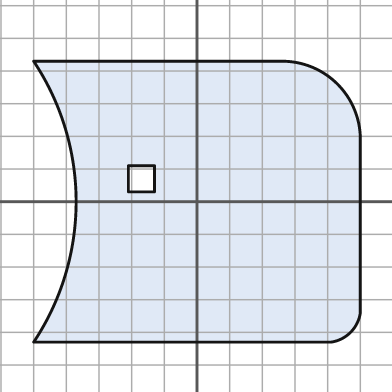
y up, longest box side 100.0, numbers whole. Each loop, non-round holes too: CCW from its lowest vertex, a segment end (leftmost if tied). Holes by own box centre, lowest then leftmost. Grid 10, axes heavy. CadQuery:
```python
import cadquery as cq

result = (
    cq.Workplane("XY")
    .moveTo(-50.0, -43.0)
    .lineTo(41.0, -43.0)
    .threePointArc((47.0, -40.0), (50.0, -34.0))
    .lineTo(50.0, 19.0)
    .threePointArc((43.0, 36.0), (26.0, 43.0))
    .lineTo(-50.0, 43.0)
    .threePointArc((-37.0, 0.0), (-50.0, -43.0))
    .close()
    .moveTo(-21.0, 3.0)
    .lineTo(-13.0, 3.0)
    .lineTo(-13.0, 11.0)
    .lineTo(-21.0, 11.0)
    .close()
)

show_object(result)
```